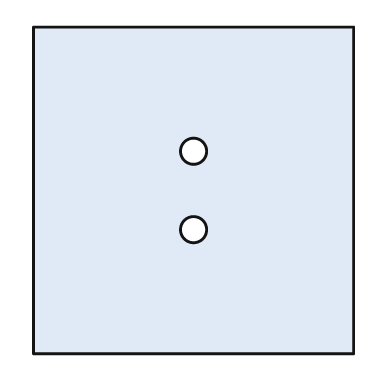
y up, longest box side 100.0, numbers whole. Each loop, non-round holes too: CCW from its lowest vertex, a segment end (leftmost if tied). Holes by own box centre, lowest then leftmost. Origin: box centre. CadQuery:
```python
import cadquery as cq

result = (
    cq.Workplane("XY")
    .moveTo(-49.0, -50.0)
    .lineTo(49.0, -50.0)
    .lineTo(49.0, 50.0)
    .lineTo(-49.0, 50.0)
    .close()
    .moveTo(0.0, -12.0)
    .circle(4.0)
    .moveTo(0.0, 12.0)
    .circle(4.0)
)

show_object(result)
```